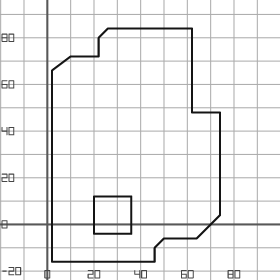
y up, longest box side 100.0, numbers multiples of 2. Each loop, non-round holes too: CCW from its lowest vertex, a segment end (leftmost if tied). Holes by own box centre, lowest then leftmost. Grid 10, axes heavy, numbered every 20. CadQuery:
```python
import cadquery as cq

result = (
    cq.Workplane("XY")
    .moveTo(2.0, -16.0)
    .lineTo(46.0, -16.0)
    .lineTo(46.0, -10.0)
    .lineTo(50.0, -6.0)
    .lineTo(64.0, -6.0)
    .lineTo(74.0, 4.0)
    .lineTo(74.0, 48.0)
    .lineTo(62.0, 48.0)
    .lineTo(62.0, 84.0)
    .lineTo(26.0, 84.0)
    .lineTo(22.0, 80.0)
    .lineTo(22.0, 72.0)
    .lineTo(10.0, 72.0)
    .lineTo(2.0, 66.0)
    .close()
    .moveTo(20.0, -4.0)
    .lineTo(36.0, -4.0)
    .lineTo(36.0, 12.0)
    .lineTo(20.0, 12.0)
    .close()
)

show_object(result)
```